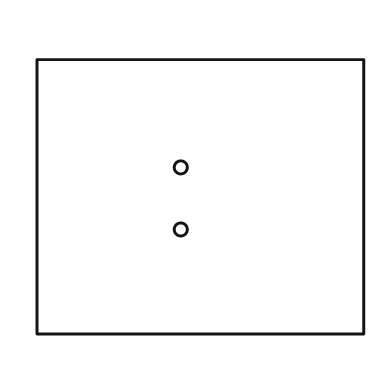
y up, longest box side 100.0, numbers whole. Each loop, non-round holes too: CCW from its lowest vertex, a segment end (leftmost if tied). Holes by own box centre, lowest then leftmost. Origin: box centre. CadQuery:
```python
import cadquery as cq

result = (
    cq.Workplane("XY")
    .moveTo(-50.0, -42.0)
    .lineTo(50.0, -42.0)
    .lineTo(50.0, 42.0)
    .lineTo(-50.0, 42.0)
    .close()
    .moveTo(-6.0, -10.0)
    .circle(2.0)
    .moveTo(-6.0, 9.0)
    .circle(2.0)
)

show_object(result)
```